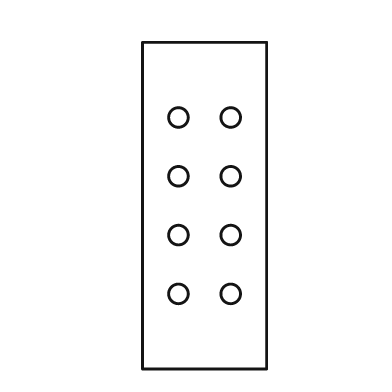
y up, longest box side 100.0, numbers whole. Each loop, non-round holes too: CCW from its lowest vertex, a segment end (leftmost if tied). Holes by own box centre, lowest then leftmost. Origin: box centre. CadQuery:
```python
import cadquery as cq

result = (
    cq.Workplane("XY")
    .moveTo(-19.0, -50.0)
    .lineTo(19.0, -50.0)
    .lineTo(19.0, 50.0)
    .lineTo(-19.0, 50.0)
    .close()
    .moveTo(-8.0, -27.0)
    .circle(3.0)
    .moveTo(8.0, -27.0)
    .circle(3.0)
    .moveTo(-8.0, -9.0)
    .circle(3.0)
    .moveTo(8.0, -9.0)
    .circle(3.0)
    .moveTo(-8.0, 9.0)
    .circle(3.0)
    .moveTo(8.0, 9.0)
    .circle(3.0)
    .moveTo(-8.0, 27.0)
    .circle(3.0)
    .moveTo(8.0, 27.0)
    .circle(3.0)
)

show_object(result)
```